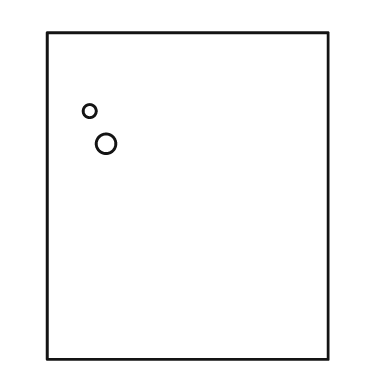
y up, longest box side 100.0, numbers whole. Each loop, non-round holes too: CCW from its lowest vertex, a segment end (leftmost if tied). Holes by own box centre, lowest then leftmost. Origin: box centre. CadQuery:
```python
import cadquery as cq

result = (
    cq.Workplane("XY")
    .moveTo(-43.0, -50.0)
    .lineTo(43.0, -50.0)
    .lineTo(43.0, 50.0)
    .lineTo(-43.0, 50.0)
    .close()
    .moveTo(-25.0, 16.0)
    .circle(3.0)
    .moveTo(-30.0, 26.0)
    .circle(2.0)
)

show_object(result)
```